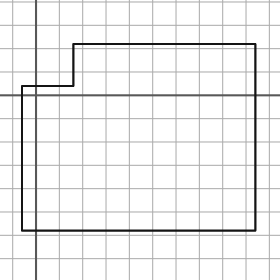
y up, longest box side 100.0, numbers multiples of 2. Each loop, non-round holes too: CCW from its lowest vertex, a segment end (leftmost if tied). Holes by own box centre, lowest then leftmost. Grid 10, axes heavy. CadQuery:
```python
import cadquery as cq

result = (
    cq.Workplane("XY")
    .moveTo(-6.0, -58.0)
    .lineTo(94.0, -58.0)
    .lineTo(94.0, 22.0)
    .lineTo(16.0, 22.0)
    .lineTo(16.0, 4.0)
    .lineTo(-6.0, 4.0)
    .close()
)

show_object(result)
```